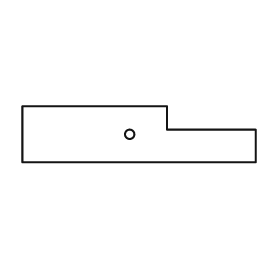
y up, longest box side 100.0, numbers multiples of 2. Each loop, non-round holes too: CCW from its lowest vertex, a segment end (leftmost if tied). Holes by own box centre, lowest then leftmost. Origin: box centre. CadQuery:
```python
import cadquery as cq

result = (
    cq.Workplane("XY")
    .moveTo(-50.0, -12.0)
    .lineTo(50.0, -12.0)
    .lineTo(50.0, 2.0)
    .lineTo(12.0, 2.0)
    .lineTo(12.0, 12.0)
    .lineTo(-50.0, 12.0)
    .close()
    .moveTo(-4.0, 0.0)
    .circle(2.0)
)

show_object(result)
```